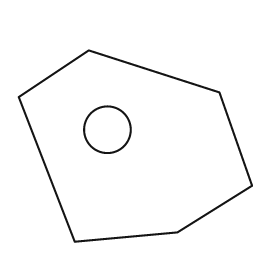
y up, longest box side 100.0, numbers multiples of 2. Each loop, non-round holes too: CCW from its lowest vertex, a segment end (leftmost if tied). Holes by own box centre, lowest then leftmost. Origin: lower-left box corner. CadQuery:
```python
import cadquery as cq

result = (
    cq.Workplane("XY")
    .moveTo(24.0, 0.0)
    .lineTo(68.0, 4.0)
    .lineTo(100.0, 24.0)
    .lineTo(86.0, 64.0)
    .lineTo(30.0, 82.0)
    .lineTo(0.0, 62.0)
    .close()
    .moveTo(38.0, 48.0)
    .circle(10.0)
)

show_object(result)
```